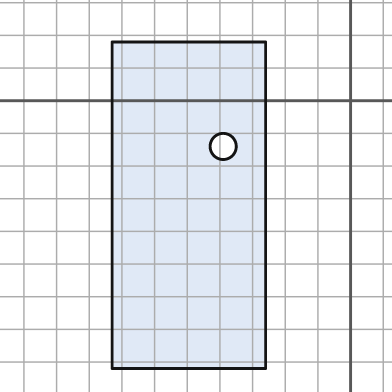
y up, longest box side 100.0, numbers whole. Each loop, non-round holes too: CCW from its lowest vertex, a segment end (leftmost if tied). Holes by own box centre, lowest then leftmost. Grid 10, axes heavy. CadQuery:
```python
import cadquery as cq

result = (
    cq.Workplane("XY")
    .moveTo(-73.0, -82.0)
    .lineTo(-26.0, -82.0)
    .lineTo(-26.0, 18.0)
    .lineTo(-73.0, 18.0)
    .close()
    .moveTo(-39.0, -14.0)
    .circle(4.0)
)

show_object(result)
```